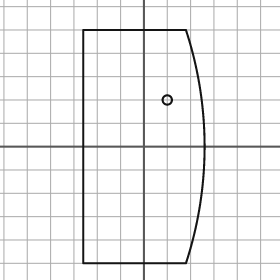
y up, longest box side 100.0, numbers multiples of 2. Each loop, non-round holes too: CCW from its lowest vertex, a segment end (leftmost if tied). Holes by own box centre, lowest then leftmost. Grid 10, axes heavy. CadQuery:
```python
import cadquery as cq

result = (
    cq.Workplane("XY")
    .moveTo(-26.0, -50.0)
    .lineTo(18.0, -50.0)
    .threePointArc((26.0, 0.0), (18.0, 50.0))
    .lineTo(-26.0, 50.0)
    .close()
    .moveTo(10.0, 20.0)
    .circle(2.0)
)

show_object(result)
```